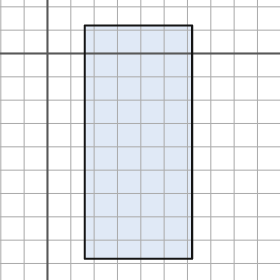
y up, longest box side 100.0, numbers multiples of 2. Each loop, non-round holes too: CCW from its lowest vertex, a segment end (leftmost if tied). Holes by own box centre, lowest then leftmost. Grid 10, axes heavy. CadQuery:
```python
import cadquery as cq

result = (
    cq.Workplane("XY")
    .moveTo(16.0, -88.0)
    .lineTo(62.0, -88.0)
    .lineTo(62.0, 12.0)
    .lineTo(16.0, 12.0)
    .close()
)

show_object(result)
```